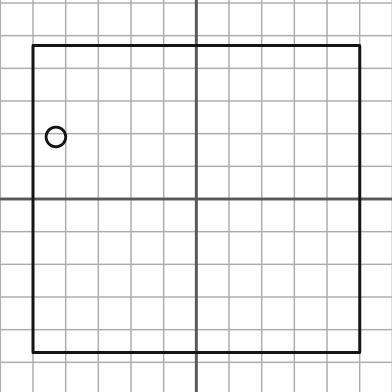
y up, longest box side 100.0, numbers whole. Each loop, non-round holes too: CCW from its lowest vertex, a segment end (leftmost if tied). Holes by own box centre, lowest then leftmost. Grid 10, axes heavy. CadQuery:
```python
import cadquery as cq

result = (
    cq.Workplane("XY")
    .moveTo(-50.0, -47.0)
    .lineTo(50.0, -47.0)
    .lineTo(50.0, 47.0)
    .lineTo(-50.0, 47.0)
    .close()
    .moveTo(-43.0, 19.0)
    .circle(3.0)
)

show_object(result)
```